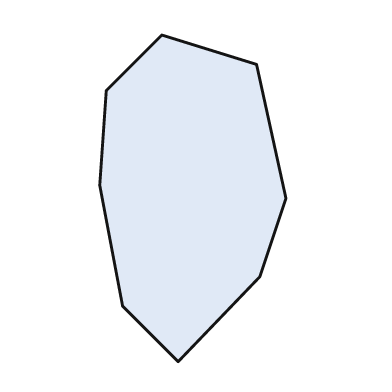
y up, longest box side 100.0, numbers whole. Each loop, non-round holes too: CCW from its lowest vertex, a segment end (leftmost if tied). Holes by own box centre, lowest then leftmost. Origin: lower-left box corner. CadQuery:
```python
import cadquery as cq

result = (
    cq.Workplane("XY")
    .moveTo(24.0, 0.0)
    .lineTo(49.0, 26.0)
    .lineTo(57.0, 50.0)
    .lineTo(48.0, 91.0)
    .lineTo(19.0, 100.0)
    .lineTo(2.0, 83.0)
    .lineTo(0.0, 54.0)
    .lineTo(7.0, 17.0)
    .close()
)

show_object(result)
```